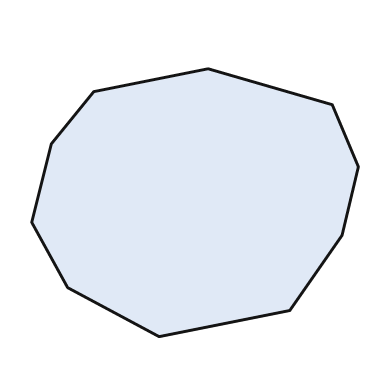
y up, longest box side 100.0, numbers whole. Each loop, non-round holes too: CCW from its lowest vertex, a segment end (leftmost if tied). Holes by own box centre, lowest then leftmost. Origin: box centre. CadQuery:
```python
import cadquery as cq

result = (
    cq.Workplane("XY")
    .moveTo(-11.0, -41.0)
    .lineTo(29.0, -33.0)
    .lineTo(45.0, -10.0)
    .lineTo(50.0, 11.0)
    .lineTo(42.0, 30.0)
    .lineTo(4.0, 41.0)
    .lineTo(-31.0, 34.0)
    .lineTo(-44.0, 18.0)
    .lineTo(-50.0, -6.0)
    .lineTo(-39.0, -26.0)
    .close()
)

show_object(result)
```